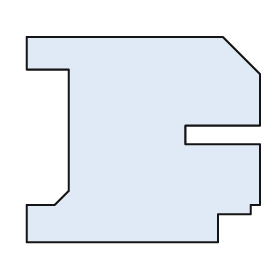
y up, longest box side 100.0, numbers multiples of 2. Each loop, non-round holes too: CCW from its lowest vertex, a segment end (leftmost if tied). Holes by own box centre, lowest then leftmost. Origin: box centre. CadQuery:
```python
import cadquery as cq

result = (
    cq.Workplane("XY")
    .moveTo(-50.0, -44.0)
    .lineTo(32.0, -44.0)
    .lineTo(32.0, -32.0)
    .lineTo(46.0, -32.0)
    .lineTo(46.0, -28.0)
    .lineTo(50.0, -28.0)
    .lineTo(50.0, -2.0)
    .lineTo(18.0, -2.0)
    .lineTo(18.0, 6.0)
    .lineTo(50.0, 6.0)
    .lineTo(50.0, 28.0)
    .lineTo(34.0, 44.0)
    .lineTo(-50.0, 44.0)
    .lineTo(-50.0, 30.0)
    .lineTo(-32.0, 30.0)
    .lineTo(-32.0, -22.0)
    .lineTo(-38.0, -28.0)
    .lineTo(-50.0, -28.0)
    .close()
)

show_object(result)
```